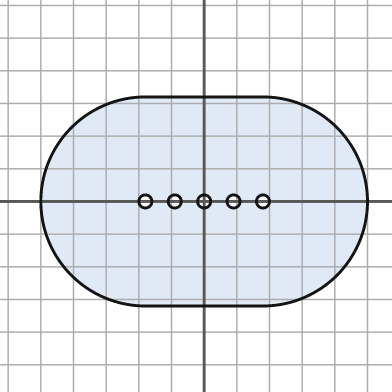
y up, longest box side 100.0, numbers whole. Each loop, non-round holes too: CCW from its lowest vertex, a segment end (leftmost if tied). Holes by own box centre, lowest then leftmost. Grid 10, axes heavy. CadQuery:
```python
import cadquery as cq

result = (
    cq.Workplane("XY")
    .moveTo(-18.0, -32.0)
    .lineTo(18.0, -32.0)
    .threePointArc((50.0, 0.0), (18.0, 32.0))
    .lineTo(-18.0, 32.0)
    .threePointArc((-50.0, 0.0), (-18.0, -32.0))
    .close()
    .moveTo(-18.0, 0.0)
    .circle(2.0)
    .moveTo(-9.0, 0.0)
    .circle(2.0)
    .moveTo(0.0, 0.0)
    .circle(2.0)
    .moveTo(9.0, 0.0)
    .circle(2.0)
    .moveTo(18.0, 0.0)
    .circle(2.0)
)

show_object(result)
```